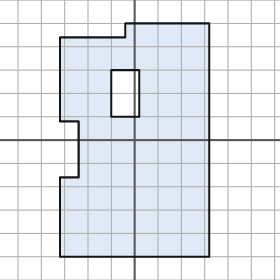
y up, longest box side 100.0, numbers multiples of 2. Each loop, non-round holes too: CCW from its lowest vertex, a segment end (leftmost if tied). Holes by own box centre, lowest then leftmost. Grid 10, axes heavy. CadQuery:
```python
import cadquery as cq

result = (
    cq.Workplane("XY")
    .moveTo(-32.0, -50.0)
    .lineTo(32.0, -50.0)
    .lineTo(32.0, 50.0)
    .lineTo(-4.0, 50.0)
    .lineTo(-4.0, 44.0)
    .lineTo(-32.0, 44.0)
    .lineTo(-32.0, 8.0)
    .lineTo(-24.0, 8.0)
    .lineTo(-24.0, -16.0)
    .lineTo(-32.0, -16.0)
    .close()
    .moveTo(-10.0, 10.0)
    .lineTo(2.0, 10.0)
    .lineTo(2.0, 30.0)
    .lineTo(-10.0, 30.0)
    .close()
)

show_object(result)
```